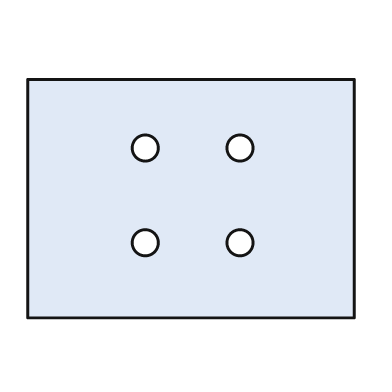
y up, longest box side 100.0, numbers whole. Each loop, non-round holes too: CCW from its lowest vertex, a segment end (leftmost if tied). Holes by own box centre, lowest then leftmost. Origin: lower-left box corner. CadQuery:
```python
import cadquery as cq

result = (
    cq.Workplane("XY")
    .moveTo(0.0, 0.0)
    .lineTo(100.0, 0.0)
    .lineTo(100.0, 73.0)
    .lineTo(0.0, 73.0)
    .close()
    .moveTo(36.0, 23.0)
    .circle(4.0)
    .moveTo(65.0, 23.0)
    .circle(4.0)
    .moveTo(36.0, 52.0)
    .circle(4.0)
    .moveTo(65.0, 52.0)
    .circle(4.0)
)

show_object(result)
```